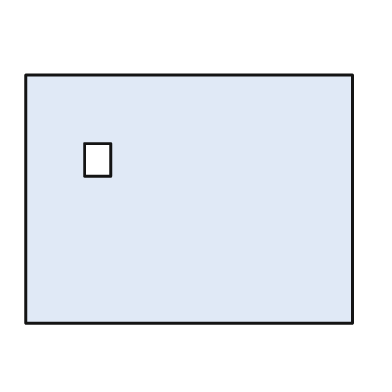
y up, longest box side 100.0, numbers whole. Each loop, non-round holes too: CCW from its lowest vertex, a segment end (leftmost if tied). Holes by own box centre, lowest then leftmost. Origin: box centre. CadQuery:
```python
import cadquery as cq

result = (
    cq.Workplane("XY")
    .moveTo(-50.0, -38.0)
    .lineTo(50.0, -38.0)
    .lineTo(50.0, 38.0)
    .lineTo(-50.0, 38.0)
    .close()
    .moveTo(-32.0, 7.0)
    .lineTo(-24.0, 7.0)
    .lineTo(-24.0, 17.0)
    .lineTo(-32.0, 17.0)
    .close()
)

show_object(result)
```